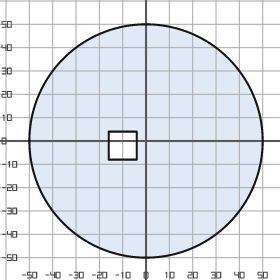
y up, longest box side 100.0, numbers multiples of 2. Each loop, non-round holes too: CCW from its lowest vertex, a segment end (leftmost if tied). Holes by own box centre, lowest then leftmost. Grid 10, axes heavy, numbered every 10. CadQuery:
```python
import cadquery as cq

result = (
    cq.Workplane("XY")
    .moveTo(0.0, 0.0)
    .circle(50.0)
    .moveTo(-16.0, -8.0)
    .lineTo(-4.0, -8.0)
    .lineTo(-4.0, 4.0)
    .lineTo(-16.0, 4.0)
    .close()
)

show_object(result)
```